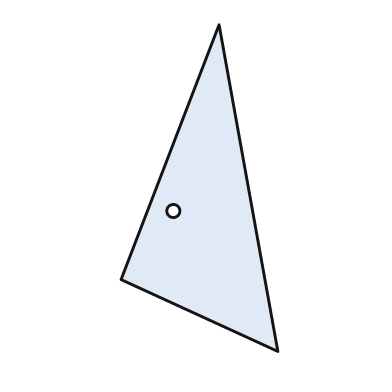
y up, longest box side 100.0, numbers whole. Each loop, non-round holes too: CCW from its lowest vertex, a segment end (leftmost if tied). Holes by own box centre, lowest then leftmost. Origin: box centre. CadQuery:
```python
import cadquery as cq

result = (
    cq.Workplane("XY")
    .moveTo(24.0, -50.0)
    .lineTo(6.0, 50.0)
    .lineTo(-24.0, -28.0)
    .close()
    .moveTo(-8.0, -7.0)
    .circle(2.0)
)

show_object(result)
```